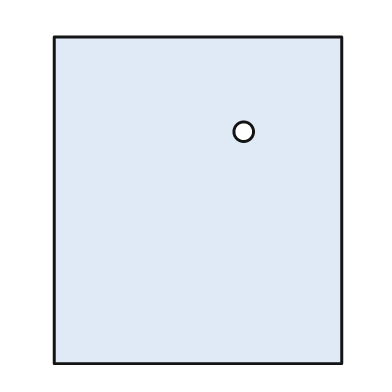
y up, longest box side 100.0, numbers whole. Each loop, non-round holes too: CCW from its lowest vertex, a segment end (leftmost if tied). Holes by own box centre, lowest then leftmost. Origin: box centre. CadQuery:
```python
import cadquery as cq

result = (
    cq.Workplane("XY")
    .moveTo(-44.0, -50.0)
    .lineTo(44.0, -50.0)
    .lineTo(44.0, 50.0)
    .lineTo(-44.0, 50.0)
    .close()
    .moveTo(14.0, 21.0)
    .circle(3.0)
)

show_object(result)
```